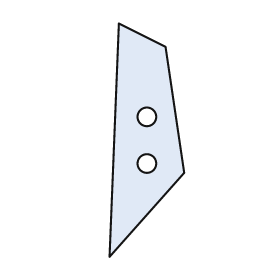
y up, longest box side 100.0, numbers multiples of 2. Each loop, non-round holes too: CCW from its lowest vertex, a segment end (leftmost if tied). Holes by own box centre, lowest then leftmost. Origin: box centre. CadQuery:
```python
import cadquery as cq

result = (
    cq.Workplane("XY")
    .moveTo(-16.0, -50.0)
    .lineTo(16.0, -14.0)
    .lineTo(8.0, 40.0)
    .lineTo(-12.0, 50.0)
    .close()
    .moveTo(0.0, -10.0)
    .circle(4.0)
    .moveTo(0.0, 10.0)
    .circle(4.0)
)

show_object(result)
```